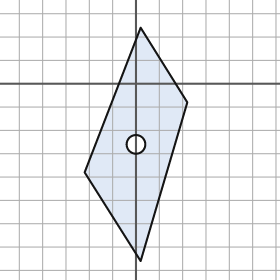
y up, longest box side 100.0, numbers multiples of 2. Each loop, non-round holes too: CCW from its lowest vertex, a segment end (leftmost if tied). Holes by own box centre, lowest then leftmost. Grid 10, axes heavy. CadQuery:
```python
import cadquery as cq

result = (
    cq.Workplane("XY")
    .moveTo(2.0, -76.0)
    .lineTo(22.0, -8.0)
    .lineTo(2.0, 24.0)
    .lineTo(-22.0, -38.0)
    .close()
    .moveTo(0.0, -26.0)
    .circle(4.0)
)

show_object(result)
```